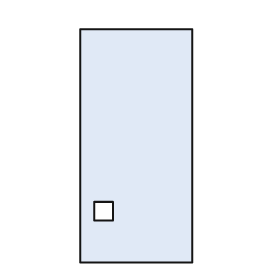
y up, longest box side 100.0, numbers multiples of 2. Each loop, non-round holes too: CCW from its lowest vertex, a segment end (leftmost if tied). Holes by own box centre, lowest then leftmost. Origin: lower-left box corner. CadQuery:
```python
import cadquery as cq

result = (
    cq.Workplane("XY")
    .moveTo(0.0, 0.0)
    .lineTo(48.0, 0.0)
    .lineTo(48.0, 100.0)
    .lineTo(0.0, 100.0)
    .close()
    .moveTo(6.0, 18.0)
    .lineTo(14.0, 18.0)
    .lineTo(14.0, 26.0)
    .lineTo(6.0, 26.0)
    .close()
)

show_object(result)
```